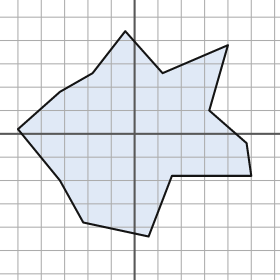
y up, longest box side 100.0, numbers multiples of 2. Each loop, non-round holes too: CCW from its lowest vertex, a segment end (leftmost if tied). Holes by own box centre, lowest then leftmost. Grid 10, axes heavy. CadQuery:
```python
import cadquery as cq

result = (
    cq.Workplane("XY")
    .moveTo(6.0, -44.0)
    .lineTo(16.0, -18.0)
    .lineTo(50.0, -18.0)
    .lineTo(48.0, -4.0)
    .lineTo(32.0, 10.0)
    .lineTo(40.0, 38.0)
    .lineTo(12.0, 26.0)
    .lineTo(-4.0, 44.0)
    .lineTo(-18.0, 26.0)
    .lineTo(-32.0, 18.0)
    .lineTo(-50.0, 2.0)
    .lineTo(-32.0, -20.0)
    .lineTo(-22.0, -38.0)
    .close()
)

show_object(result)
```